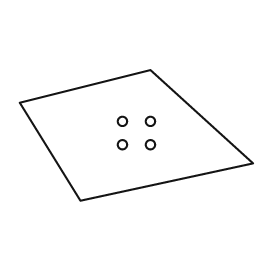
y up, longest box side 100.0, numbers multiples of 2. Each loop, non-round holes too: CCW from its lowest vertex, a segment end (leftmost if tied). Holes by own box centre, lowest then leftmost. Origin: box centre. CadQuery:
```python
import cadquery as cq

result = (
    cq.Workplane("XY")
    .moveTo(-24.0, -28.0)
    .lineTo(50.0, -12.0)
    .lineTo(6.0, 28.0)
    .lineTo(-50.0, 14.0)
    .close()
    .moveTo(-6.0, -4.0)
    .circle(2.0)
    .moveTo(6.0, -4.0)
    .circle(2.0)
    .moveTo(-6.0, 6.0)
    .circle(2.0)
    .moveTo(6.0, 6.0)
    .circle(2.0)
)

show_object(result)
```